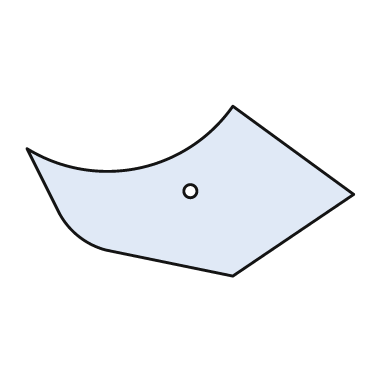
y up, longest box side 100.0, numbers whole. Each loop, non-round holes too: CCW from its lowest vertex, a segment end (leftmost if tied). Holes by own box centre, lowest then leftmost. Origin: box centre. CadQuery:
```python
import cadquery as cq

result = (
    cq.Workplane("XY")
    .moveTo(13.0, -26.0)
    .lineTo(50.0, -1.0)
    .lineTo(13.0, 26.0)
    .threePointArc((-16.0, 7.0), (-50.0, 13.0))
    .lineTo(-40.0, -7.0)
    .threePointArc((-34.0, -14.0), (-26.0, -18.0))
    .close()
    .moveTo(0.0, 0.0)
    .circle(2.0)
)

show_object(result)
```